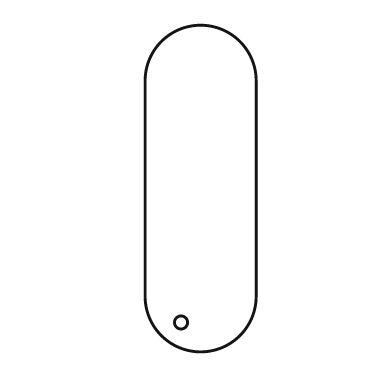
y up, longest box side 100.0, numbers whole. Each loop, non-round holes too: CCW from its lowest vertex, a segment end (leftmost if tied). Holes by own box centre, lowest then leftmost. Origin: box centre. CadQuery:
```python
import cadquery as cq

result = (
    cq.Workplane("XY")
    .moveTo(-17.0, -33.0)
    .threePointArc((0.0, -50.0), (17.0, -33.0))
    .lineTo(17.0, 33.0)
    .threePointArc((0.0, 50.0), (-17.0, 33.0))
    .close()
    .moveTo(-6.0, -41.0)
    .circle(2.0)
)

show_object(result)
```